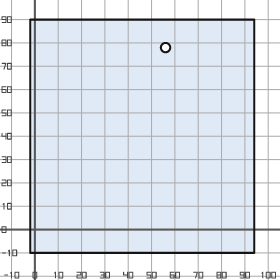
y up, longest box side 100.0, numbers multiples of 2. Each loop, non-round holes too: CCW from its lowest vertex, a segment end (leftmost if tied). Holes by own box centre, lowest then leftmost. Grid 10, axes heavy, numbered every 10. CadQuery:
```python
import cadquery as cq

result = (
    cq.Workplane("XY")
    .moveTo(-2.0, -10.0)
    .lineTo(94.0, -10.0)
    .lineTo(94.0, 90.0)
    .lineTo(-2.0, 90.0)
    .close()
    .moveTo(56.0, 78.0)
    .circle(2.0)
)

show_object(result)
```